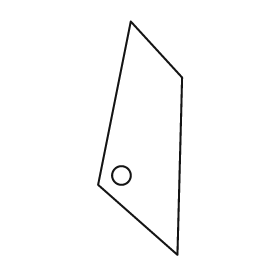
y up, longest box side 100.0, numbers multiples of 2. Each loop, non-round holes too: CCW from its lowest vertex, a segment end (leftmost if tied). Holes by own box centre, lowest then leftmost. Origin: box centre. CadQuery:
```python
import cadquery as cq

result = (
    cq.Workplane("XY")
    .moveTo(16.0, -50.0)
    .lineTo(18.0, 26.0)
    .lineTo(-4.0, 50.0)
    .lineTo(-18.0, -20.0)
    .close()
    .moveTo(-8.0, -16.0)
    .circle(4.0)
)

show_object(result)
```